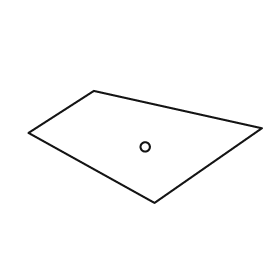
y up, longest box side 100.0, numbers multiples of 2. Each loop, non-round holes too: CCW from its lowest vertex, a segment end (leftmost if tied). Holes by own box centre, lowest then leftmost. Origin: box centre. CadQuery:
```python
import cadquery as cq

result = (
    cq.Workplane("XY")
    .moveTo(4.0, -24.0)
    .lineTo(50.0, 8.0)
    .lineTo(-22.0, 24.0)
    .lineTo(-50.0, 6.0)
    .close()
    .moveTo(0.0, 0.0)
    .circle(2.0)
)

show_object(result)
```